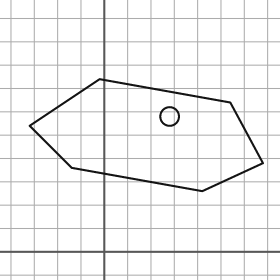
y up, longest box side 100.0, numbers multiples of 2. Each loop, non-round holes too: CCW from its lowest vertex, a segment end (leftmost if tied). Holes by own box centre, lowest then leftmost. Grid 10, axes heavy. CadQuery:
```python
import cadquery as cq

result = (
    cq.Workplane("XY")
    .moveTo(42.0, 26.0)
    .lineTo(68.0, 38.0)
    .lineTo(54.0, 64.0)
    .lineTo(-2.0, 74.0)
    .lineTo(-32.0, 54.0)
    .lineTo(-14.0, 36.0)
    .close()
    .moveTo(28.0, 58.0)
    .circle(4.0)
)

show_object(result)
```